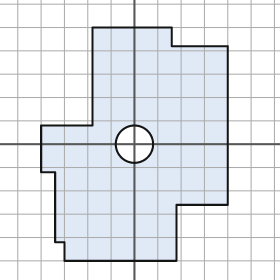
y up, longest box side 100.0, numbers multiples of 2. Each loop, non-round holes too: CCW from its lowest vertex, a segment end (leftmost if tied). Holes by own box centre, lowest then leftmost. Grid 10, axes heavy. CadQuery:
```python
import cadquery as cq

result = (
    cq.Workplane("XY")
    .moveTo(-30.0, -50.0)
    .lineTo(18.0, -50.0)
    .lineTo(18.0, -26.0)
    .lineTo(40.0, -26.0)
    .lineTo(40.0, 42.0)
    .lineTo(16.0, 42.0)
    .lineTo(16.0, 50.0)
    .lineTo(-18.0, 50.0)
    .lineTo(-18.0, 8.0)
    .lineTo(-40.0, 8.0)
    .lineTo(-40.0, -12.0)
    .lineTo(-34.0, -12.0)
    .lineTo(-34.0, -42.0)
    .lineTo(-30.0, -42.0)
    .close()
    .moveTo(0.0, 0.0)
    .circle(8.0)
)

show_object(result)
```